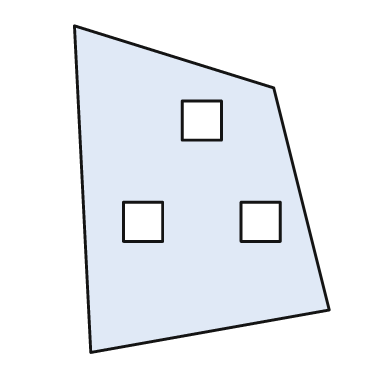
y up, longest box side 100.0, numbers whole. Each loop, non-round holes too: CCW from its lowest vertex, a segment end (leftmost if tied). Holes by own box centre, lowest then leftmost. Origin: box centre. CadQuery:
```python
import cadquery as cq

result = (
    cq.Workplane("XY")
    .moveTo(-34.0, -50.0)
    .lineTo(39.0, -37.0)
    .lineTo(22.0, 31.0)
    .lineTo(-39.0, 50.0)
    .close()
    .moveTo(-24.0, -16.0)
    .lineTo(-12.0, -16.0)
    .lineTo(-12.0, -4.0)
    .lineTo(-24.0, -4.0)
    .close()
    .moveTo(12.0, -16.0)
    .lineTo(24.0, -16.0)
    .lineTo(24.0, -4.0)
    .lineTo(12.0, -4.0)
    .close()
    .moveTo(-6.0, 15.0)
    .lineTo(6.0, 15.0)
    .lineTo(6.0, 27.0)
    .lineTo(-6.0, 27.0)
    .close()
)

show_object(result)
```